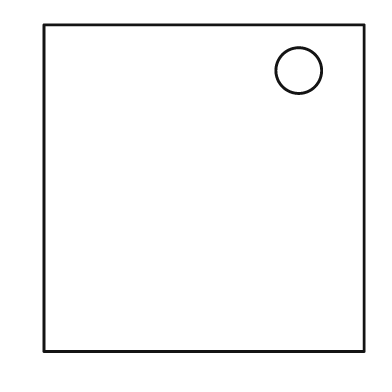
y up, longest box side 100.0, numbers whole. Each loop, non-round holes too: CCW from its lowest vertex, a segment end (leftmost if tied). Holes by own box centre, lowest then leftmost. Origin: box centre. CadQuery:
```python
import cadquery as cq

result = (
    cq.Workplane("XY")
    .moveTo(-49.0, -50.0)
    .lineTo(49.0, -50.0)
    .lineTo(49.0, 50.0)
    .lineTo(-49.0, 50.0)
    .close()
    .moveTo(29.0, 36.0)
    .circle(7.0)
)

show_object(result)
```